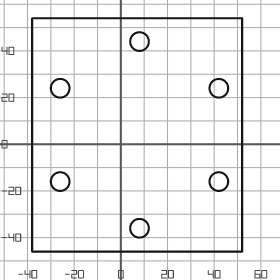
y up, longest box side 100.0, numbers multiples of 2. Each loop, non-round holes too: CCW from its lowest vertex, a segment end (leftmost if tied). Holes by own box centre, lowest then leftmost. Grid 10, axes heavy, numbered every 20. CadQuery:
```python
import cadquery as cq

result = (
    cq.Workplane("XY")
    .moveTo(-38.0, -46.0)
    .lineTo(52.0, -46.0)
    .lineTo(52.0, 54.0)
    .lineTo(-38.0, 54.0)
    .close()
    .moveTo(8.0, -36.0)
    .circle(4.0)
    .moveTo(-26.0, -16.0)
    .circle(4.0)
    .moveTo(42.0, -16.0)
    .circle(4.0)
    .moveTo(-26.0, 24.0)
    .circle(4.0)
    .moveTo(42.0, 24.0)
    .circle(4.0)
    .moveTo(8.0, 44.0)
    .circle(4.0)
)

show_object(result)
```